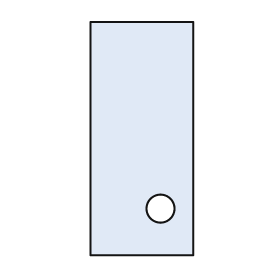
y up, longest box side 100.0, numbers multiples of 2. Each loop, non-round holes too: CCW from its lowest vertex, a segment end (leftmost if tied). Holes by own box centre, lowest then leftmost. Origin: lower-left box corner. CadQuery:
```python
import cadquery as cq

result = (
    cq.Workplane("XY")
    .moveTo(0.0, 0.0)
    .lineTo(44.0, 0.0)
    .lineTo(44.0, 100.0)
    .lineTo(0.0, 100.0)
    .close()
    .moveTo(30.0, 20.0)
    .circle(6.0)
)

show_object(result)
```